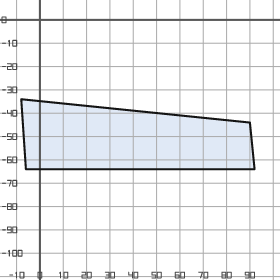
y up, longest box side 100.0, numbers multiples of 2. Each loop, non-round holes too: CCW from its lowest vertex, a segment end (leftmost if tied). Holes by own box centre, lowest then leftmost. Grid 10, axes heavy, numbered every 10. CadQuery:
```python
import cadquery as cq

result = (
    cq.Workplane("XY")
    .moveTo(-6.0, -64.0)
    .lineTo(92.0, -64.0)
    .lineTo(90.0, -44.0)
    .lineTo(-8.0, -34.0)
    .close()
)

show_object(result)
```